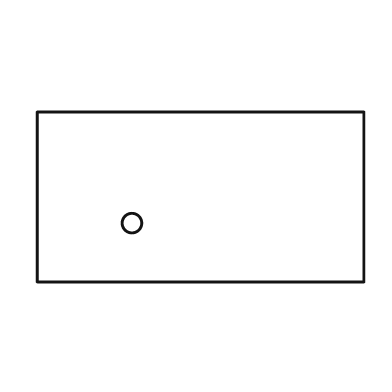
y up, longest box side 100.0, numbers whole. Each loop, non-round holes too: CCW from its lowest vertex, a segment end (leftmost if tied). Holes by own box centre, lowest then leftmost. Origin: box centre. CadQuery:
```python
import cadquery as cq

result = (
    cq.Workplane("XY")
    .moveTo(-50.0, -26.0)
    .lineTo(50.0, -26.0)
    .lineTo(50.0, 26.0)
    .lineTo(-50.0, 26.0)
    .close()
    .moveTo(-21.0, -8.0)
    .circle(3.0)
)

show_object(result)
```